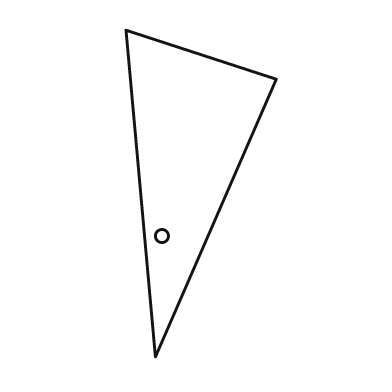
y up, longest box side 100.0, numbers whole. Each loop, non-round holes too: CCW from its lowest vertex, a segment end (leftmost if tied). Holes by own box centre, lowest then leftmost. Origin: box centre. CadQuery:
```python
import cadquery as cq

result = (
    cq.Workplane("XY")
    .moveTo(-14.0, -50.0)
    .lineTo(23.0, 35.0)
    .lineTo(-23.0, 50.0)
    .close()
    .moveTo(-12.0, -13.0)
    .circle(2.0)
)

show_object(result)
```